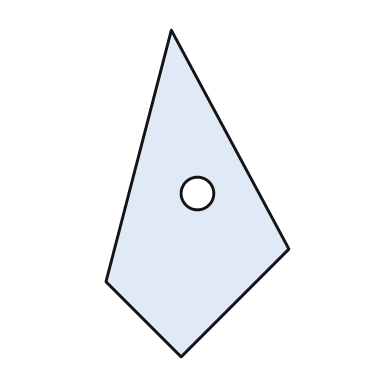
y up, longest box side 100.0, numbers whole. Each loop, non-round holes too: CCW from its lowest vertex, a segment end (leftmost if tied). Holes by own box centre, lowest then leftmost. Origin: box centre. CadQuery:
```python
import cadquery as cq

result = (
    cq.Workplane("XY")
    .moveTo(-5.0, -50.0)
    .lineTo(28.0, -17.0)
    .lineTo(-8.0, 50.0)
    .lineTo(-28.0, -27.0)
    .close()
    .moveTo(0.0, 0.0)
    .circle(5.0)
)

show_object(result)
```